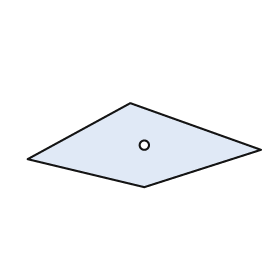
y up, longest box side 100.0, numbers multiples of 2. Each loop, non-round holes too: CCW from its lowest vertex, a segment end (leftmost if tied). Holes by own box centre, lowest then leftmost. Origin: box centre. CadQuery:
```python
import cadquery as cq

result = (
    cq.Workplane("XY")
    .moveTo(0.0, -18.0)
    .lineTo(50.0, -2.0)
    .lineTo(-6.0, 18.0)
    .lineTo(-50.0, -6.0)
    .close()
    .moveTo(0.0, 0.0)
    .circle(2.0)
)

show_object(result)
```